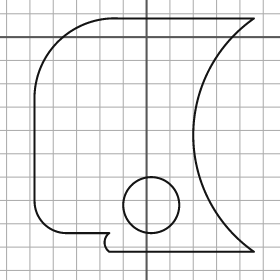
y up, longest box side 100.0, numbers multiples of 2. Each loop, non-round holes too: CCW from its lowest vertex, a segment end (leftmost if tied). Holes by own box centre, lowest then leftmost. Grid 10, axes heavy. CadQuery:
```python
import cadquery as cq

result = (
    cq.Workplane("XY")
    .moveTo(-16.0, -92.0)
    .lineTo(46.0, -92.0)
    .threePointArc((20.0, -42.0), (46.0, 8.0))
    .lineTo(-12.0, 8.0)
    .threePointArc((-38.0, -2.0), (-48.0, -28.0))
    .lineTo(-48.0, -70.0)
    .threePointArc((-44.0, -80.0), (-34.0, -84.0))
    .lineTo(-16.0, -84.0)
    .threePointArc((-18.0, -88.0), (-16.0, -92.0))
    .close()
    .moveTo(2.0, -72.0)
    .circle(12.0)
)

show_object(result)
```